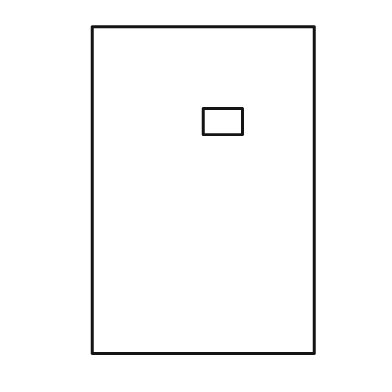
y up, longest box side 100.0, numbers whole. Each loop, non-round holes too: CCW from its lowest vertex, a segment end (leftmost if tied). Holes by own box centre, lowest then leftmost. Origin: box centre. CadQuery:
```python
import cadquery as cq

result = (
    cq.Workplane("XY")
    .moveTo(-34.0, -50.0)
    .lineTo(34.0, -50.0)
    .lineTo(34.0, 50.0)
    .lineTo(-34.0, 50.0)
    .close()
    .moveTo(0.0, 17.0)
    .lineTo(12.0, 17.0)
    .lineTo(12.0, 25.0)
    .lineTo(0.0, 25.0)
    .close()
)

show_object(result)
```